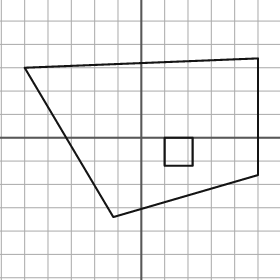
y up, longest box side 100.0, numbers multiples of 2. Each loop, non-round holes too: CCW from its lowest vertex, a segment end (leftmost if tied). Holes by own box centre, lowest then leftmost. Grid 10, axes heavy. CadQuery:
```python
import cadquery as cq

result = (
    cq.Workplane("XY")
    .moveTo(-12.0, -34.0)
    .lineTo(50.0, -16.0)
    .lineTo(50.0, 34.0)
    .lineTo(-50.0, 30.0)
    .close()
    .moveTo(10.0, -12.0)
    .lineTo(22.0, -12.0)
    .lineTo(22.0, 0.0)
    .lineTo(10.0, 0.0)
    .close()
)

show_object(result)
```